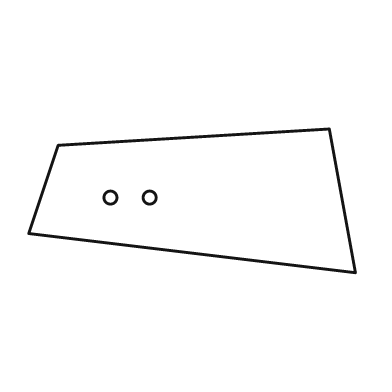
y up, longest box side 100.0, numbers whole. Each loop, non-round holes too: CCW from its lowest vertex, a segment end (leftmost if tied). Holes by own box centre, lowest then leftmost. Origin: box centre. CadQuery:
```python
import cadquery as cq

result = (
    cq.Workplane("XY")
    .moveTo(50.0, -22.0)
    .lineTo(42.0, 22.0)
    .lineTo(-41.0, 17.0)
    .lineTo(-50.0, -10.0)
    .close()
    .moveTo(-25.0, 1.0)
    .circle(2.0)
    .moveTo(-13.0, 1.0)
    .circle(2.0)
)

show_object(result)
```